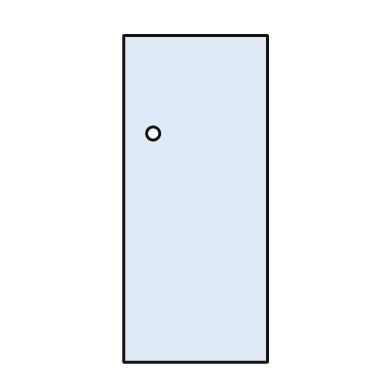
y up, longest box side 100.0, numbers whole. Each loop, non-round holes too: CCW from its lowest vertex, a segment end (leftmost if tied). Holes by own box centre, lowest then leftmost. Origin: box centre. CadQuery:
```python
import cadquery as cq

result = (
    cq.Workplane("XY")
    .moveTo(-22.0, -50.0)
    .lineTo(22.0, -50.0)
    .lineTo(22.0, 50.0)
    .lineTo(-22.0, 50.0)
    .close()
    .moveTo(-13.0, 20.0)
    .circle(2.0)
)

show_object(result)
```